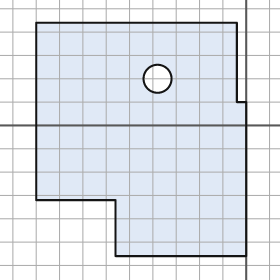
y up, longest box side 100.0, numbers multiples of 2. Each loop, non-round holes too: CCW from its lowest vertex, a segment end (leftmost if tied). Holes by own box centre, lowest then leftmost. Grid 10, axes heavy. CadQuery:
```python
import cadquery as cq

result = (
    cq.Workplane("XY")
    .moveTo(-56.0, -56.0)
    .lineTo(0.0, -56.0)
    .lineTo(0.0, 10.0)
    .lineTo(-4.0, 10.0)
    .lineTo(-4.0, 44.0)
    .lineTo(-90.0, 44.0)
    .lineTo(-90.0, -32.0)
    .lineTo(-56.0, -32.0)
    .close()
    .moveTo(-38.0, 20.0)
    .circle(6.0)
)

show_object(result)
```